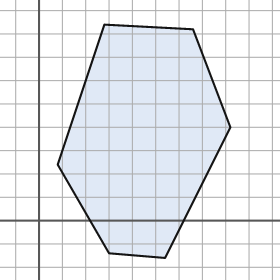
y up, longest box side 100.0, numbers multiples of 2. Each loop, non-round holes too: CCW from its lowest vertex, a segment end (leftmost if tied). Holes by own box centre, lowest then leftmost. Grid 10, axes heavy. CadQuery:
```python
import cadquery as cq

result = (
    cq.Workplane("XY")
    .moveTo(54.0, -16.0)
    .lineTo(82.0, 40.0)
    .lineTo(66.0, 82.0)
    .lineTo(28.0, 84.0)
    .lineTo(8.0, 24.0)
    .lineTo(30.0, -14.0)
    .close()
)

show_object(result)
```